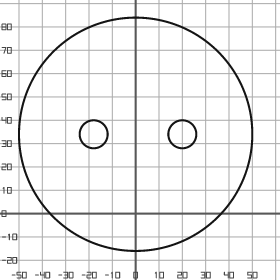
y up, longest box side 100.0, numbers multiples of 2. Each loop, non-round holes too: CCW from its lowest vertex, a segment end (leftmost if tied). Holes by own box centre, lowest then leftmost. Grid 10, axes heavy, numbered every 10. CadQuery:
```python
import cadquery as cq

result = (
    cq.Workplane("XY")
    .moveTo(0.0, 34.0)
    .circle(50.0)
    .moveTo(-18.0, 34.0)
    .circle(6.0)
    .moveTo(20.0, 34.0)
    .circle(6.0)
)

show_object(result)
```